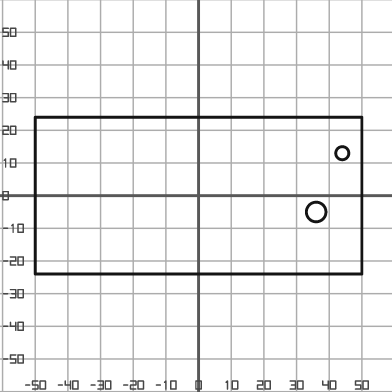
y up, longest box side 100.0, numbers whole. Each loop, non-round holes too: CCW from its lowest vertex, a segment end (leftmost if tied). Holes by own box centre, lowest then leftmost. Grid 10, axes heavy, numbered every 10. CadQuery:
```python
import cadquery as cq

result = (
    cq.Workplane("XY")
    .moveTo(-50.0, -24.0)
    .lineTo(50.0, -24.0)
    .lineTo(50.0, 24.0)
    .lineTo(-50.0, 24.0)
    .close()
    .moveTo(36.0, -5.0)
    .circle(3.0)
    .moveTo(44.0, 13.0)
    .circle(2.0)
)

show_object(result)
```